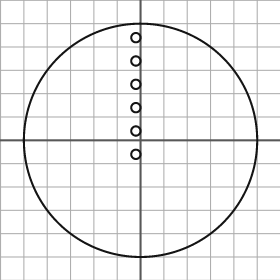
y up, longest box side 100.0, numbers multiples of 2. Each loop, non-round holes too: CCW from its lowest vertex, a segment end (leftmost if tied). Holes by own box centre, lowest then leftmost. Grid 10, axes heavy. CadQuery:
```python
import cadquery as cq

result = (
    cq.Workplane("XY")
    .moveTo(0.0, 0.0)
    .circle(50.0)
    .moveTo(-2.0, -6.0)
    .circle(2.0)
    .moveTo(-2.0, 4.0)
    .circle(2.0)
    .moveTo(-2.0, 14.0)
    .circle(2.0)
    .moveTo(-2.0, 24.0)
    .circle(2.0)
    .moveTo(-2.0, 34.0)
    .circle(2.0)
    .moveTo(-2.0, 44.0)
    .circle(2.0)
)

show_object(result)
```